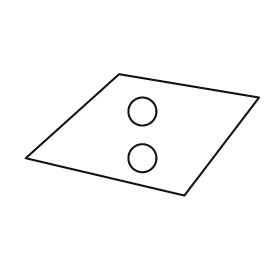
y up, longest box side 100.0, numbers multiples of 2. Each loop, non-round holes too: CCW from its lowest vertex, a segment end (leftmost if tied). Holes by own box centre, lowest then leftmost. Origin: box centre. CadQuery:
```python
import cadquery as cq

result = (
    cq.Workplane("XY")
    .moveTo(18.0, -26.0)
    .lineTo(50.0, 16.0)
    .lineTo(-10.0, 26.0)
    .lineTo(-50.0, -10.0)
    .close()
    .moveTo(0.0, -10.0)
    .circle(6.0)
    .moveTo(0.0, 10.0)
    .circle(6.0)
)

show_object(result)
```